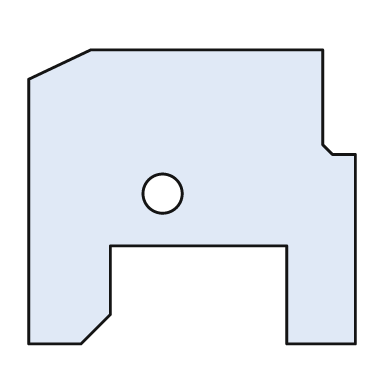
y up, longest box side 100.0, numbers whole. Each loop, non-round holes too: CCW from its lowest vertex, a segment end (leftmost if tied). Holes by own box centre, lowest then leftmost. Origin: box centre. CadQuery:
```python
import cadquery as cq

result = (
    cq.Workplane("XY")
    .moveTo(-50.0, -45.0)
    .lineTo(-34.0, -45.0)
    .lineTo(-25.0, -36.0)
    .lineTo(-25.0, -15.0)
    .lineTo(29.0, -15.0)
    .lineTo(29.0, -45.0)
    .lineTo(50.0, -45.0)
    .lineTo(50.0, 13.0)
    .lineTo(43.0, 13.0)
    .lineTo(40.0, 16.0)
    .lineTo(40.0, 45.0)
    .lineTo(-31.0, 45.0)
    .lineTo(-50.0, 36.0)
    .close()
    .moveTo(-9.0, 1.0)
    .circle(6.0)
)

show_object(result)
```